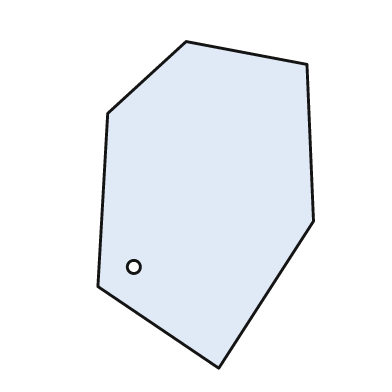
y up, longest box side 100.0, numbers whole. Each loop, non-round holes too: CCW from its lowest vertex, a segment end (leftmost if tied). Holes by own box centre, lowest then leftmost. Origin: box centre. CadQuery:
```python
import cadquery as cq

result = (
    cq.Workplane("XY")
    .moveTo(4.0, -50.0)
    .lineTo(33.0, -5.0)
    .lineTo(31.0, 43.0)
    .lineTo(-6.0, 50.0)
    .lineTo(-30.0, 28.0)
    .lineTo(-33.0, -25.0)
    .close()
    .moveTo(-22.0, -19.0)
    .circle(2.0)
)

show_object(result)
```